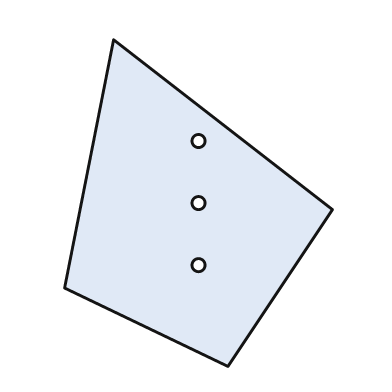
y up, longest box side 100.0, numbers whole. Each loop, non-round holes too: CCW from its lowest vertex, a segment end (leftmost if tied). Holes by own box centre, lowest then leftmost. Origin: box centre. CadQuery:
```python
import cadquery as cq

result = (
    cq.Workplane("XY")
    .moveTo(9.0, -50.0)
    .lineTo(41.0, -2.0)
    .lineTo(-26.0, 50.0)
    .lineTo(-41.0, -26.0)
    .close()
    .moveTo(0.0, -19.0)
    .circle(2.0)
    .moveTo(0.0, 0.0)
    .circle(2.0)
    .moveTo(0.0, 19.0)
    .circle(2.0)
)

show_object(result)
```